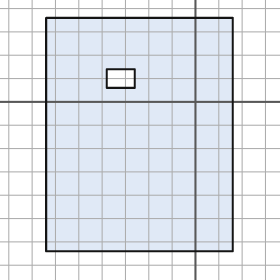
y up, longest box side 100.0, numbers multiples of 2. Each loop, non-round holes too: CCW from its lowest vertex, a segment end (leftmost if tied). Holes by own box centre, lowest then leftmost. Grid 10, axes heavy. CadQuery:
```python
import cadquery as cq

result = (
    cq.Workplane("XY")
    .moveTo(-64.0, -64.0)
    .lineTo(16.0, -64.0)
    .lineTo(16.0, 36.0)
    .lineTo(-64.0, 36.0)
    .close()
    .moveTo(-38.0, 6.0)
    .lineTo(-26.0, 6.0)
    .lineTo(-26.0, 14.0)
    .lineTo(-38.0, 14.0)
    .close()
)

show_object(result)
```